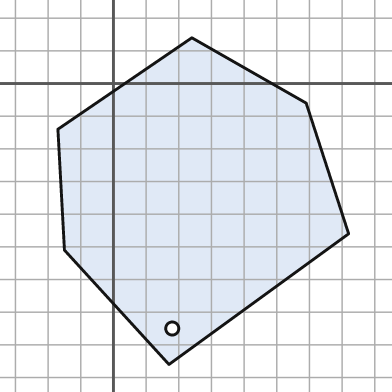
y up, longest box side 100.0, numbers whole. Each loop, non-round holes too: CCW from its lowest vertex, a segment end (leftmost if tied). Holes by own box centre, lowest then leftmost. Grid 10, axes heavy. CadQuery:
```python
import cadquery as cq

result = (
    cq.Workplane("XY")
    .moveTo(17.0, -86.0)
    .lineTo(72.0, -46.0)
    .lineTo(59.0, -6.0)
    .lineTo(24.0, 14.0)
    .lineTo(-17.0, -14.0)
    .lineTo(-15.0, -51.0)
    .close()
    .moveTo(18.0, -75.0)
    .circle(2.0)
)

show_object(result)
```